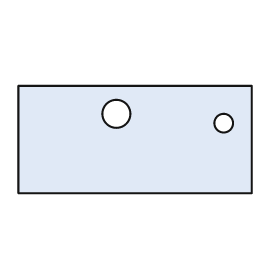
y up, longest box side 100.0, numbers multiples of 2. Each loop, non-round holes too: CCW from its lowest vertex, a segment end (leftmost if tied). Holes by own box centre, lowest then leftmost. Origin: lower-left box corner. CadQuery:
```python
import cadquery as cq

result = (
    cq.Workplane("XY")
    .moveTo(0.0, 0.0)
    .lineTo(100.0, 0.0)
    .lineTo(100.0, 46.0)
    .lineTo(0.0, 46.0)
    .close()
    .moveTo(88.0, 30.0)
    .circle(4.0)
    .moveTo(42.0, 34.0)
    .circle(6.0)
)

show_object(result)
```